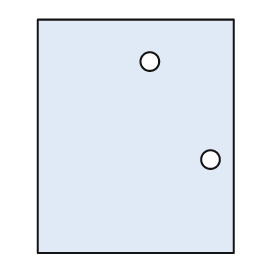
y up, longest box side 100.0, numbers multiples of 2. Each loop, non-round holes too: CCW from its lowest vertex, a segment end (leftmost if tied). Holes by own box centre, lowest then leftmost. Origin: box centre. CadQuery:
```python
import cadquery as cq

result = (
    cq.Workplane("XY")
    .moveTo(-42.0, -50.0)
    .lineTo(42.0, -50.0)
    .lineTo(42.0, 50.0)
    .lineTo(-42.0, 50.0)
    .close()
    .moveTo(32.0, -10.0)
    .circle(4.0)
    .moveTo(6.0, 32.0)
    .circle(4.0)
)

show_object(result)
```